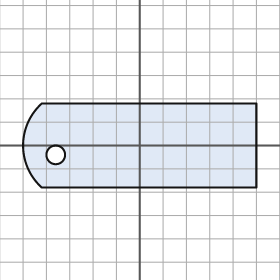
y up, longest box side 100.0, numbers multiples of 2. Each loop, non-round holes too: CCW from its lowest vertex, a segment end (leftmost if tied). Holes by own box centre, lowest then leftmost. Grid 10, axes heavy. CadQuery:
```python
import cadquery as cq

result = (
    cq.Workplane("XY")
    .moveTo(-42.0, -18.0)
    .lineTo(50.0, -18.0)
    .lineTo(50.0, 18.0)
    .lineTo(-42.0, 18.0)
    .threePointArc((-50.0, 0.0), (-42.0, -18.0))
    .close()
    .moveTo(-36.0, -4.0)
    .circle(4.0)
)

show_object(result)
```